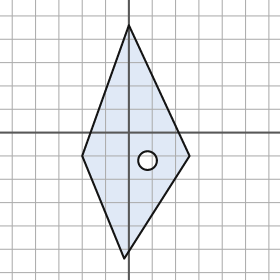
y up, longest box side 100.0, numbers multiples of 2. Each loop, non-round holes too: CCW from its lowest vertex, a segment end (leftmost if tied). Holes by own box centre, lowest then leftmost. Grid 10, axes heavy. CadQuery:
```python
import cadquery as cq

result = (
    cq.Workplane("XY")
    .moveTo(-2.0, -54.0)
    .lineTo(26.0, -10.0)
    .lineTo(0.0, 46.0)
    .lineTo(-20.0, -10.0)
    .close()
    .moveTo(8.0, -12.0)
    .circle(4.0)
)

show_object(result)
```